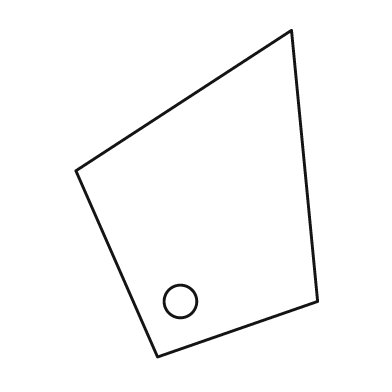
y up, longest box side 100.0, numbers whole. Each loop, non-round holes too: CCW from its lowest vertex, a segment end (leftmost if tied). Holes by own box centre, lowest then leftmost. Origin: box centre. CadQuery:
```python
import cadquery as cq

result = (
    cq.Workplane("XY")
    .moveTo(-12.0, -50.0)
    .lineTo(37.0, -33.0)
    .lineTo(29.0, 50.0)
    .lineTo(-37.0, 7.0)
    .close()
    .moveTo(-5.0, -33.0)
    .circle(5.0)
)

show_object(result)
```